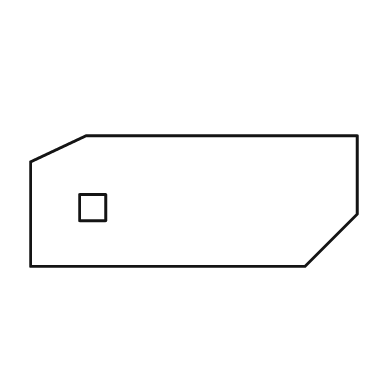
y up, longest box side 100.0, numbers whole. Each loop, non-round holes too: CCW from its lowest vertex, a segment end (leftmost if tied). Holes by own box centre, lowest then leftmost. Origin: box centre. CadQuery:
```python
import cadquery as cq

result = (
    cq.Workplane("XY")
    .moveTo(-50.0, -20.0)
    .lineTo(34.0, -20.0)
    .lineTo(50.0, -4.0)
    .lineTo(50.0, 20.0)
    .lineTo(-33.0, 20.0)
    .lineTo(-50.0, 12.0)
    .close()
    .moveTo(-35.0, -6.0)
    .lineTo(-27.0, -6.0)
    .lineTo(-27.0, 2.0)
    .lineTo(-35.0, 2.0)
    .close()
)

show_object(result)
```